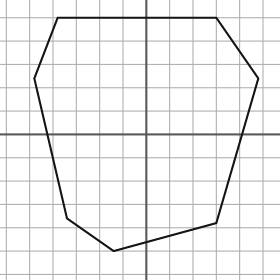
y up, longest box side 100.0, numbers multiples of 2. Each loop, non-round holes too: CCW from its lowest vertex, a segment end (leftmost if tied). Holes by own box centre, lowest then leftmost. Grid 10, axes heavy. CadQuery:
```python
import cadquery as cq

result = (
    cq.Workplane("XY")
    .moveTo(-14.0, -50.0)
    .lineTo(30.0, -38.0)
    .lineTo(48.0, 24.0)
    .lineTo(30.0, 50.0)
    .lineTo(-38.0, 50.0)
    .lineTo(-48.0, 24.0)
    .lineTo(-34.0, -36.0)
    .close()
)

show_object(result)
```